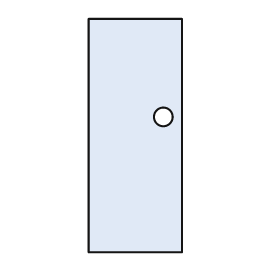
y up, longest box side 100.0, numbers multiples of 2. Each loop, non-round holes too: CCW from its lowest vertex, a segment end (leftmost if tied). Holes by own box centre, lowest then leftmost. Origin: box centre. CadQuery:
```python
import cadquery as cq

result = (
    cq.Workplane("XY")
    .moveTo(-20.0, -50.0)
    .lineTo(20.0, -50.0)
    .lineTo(20.0, 50.0)
    .lineTo(-20.0, 50.0)
    .close()
    .moveTo(12.0, 8.0)
    .circle(4.0)
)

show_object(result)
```